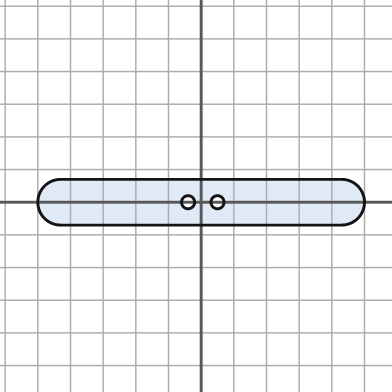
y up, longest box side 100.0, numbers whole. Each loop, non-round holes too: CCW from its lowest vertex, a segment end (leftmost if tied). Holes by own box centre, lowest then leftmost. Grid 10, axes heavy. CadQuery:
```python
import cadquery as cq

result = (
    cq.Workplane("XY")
    .moveTo(-43.0, -7.0)
    .lineTo(43.0, -7.0)
    .threePointArc((50.0, 0.0), (43.0, 7.0))
    .lineTo(-43.0, 7.0)
    .threePointArc((-50.0, 0.0), (-43.0, -7.0))
    .close()
    .moveTo(-4.0, 0.0)
    .circle(2.0)
    .moveTo(5.0, 0.0)
    .circle(2.0)
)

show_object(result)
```